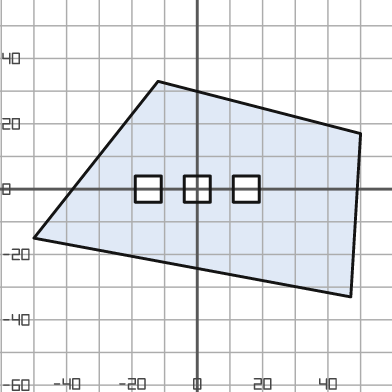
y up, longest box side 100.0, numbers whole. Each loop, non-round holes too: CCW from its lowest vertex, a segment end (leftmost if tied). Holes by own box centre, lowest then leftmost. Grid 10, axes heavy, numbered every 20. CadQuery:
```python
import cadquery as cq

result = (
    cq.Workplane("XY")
    .moveTo(47.0, -33.0)
    .lineTo(50.0, 17.0)
    .lineTo(-12.0, 33.0)
    .lineTo(-50.0, -15.0)
    .close()
    .moveTo(-19.0, -4.0)
    .lineTo(-11.0, -4.0)
    .lineTo(-11.0, 4.0)
    .lineTo(-19.0, 4.0)
    .close()
    .moveTo(-4.0, -4.0)
    .lineTo(4.0, -4.0)
    .lineTo(4.0, 4.0)
    .lineTo(-4.0, 4.0)
    .close()
    .moveTo(11.0, -4.0)
    .lineTo(19.0, -4.0)
    .lineTo(19.0, 4.0)
    .lineTo(11.0, 4.0)
    .close()
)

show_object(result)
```